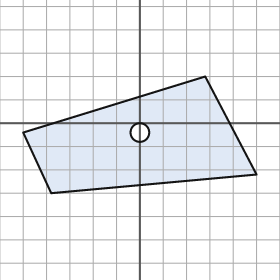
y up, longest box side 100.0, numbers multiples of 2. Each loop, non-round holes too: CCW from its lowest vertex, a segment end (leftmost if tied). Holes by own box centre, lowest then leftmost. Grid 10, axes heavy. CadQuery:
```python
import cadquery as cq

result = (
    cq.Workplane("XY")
    .moveTo(-38.0, -30.0)
    .lineTo(50.0, -22.0)
    .lineTo(28.0, 20.0)
    .lineTo(-50.0, -4.0)
    .close()
    .moveTo(0.0, -4.0)
    .circle(4.0)
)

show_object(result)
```